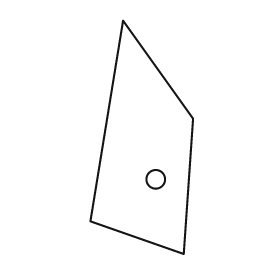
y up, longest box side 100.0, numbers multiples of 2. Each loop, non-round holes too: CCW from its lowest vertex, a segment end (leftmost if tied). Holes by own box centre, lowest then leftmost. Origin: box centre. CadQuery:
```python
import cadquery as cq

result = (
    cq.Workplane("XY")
    .moveTo(18.0, -50.0)
    .lineTo(22.0, 8.0)
    .lineTo(-8.0, 50.0)
    .lineTo(-22.0, -36.0)
    .close()
    .moveTo(6.0, -18.0)
    .circle(4.0)
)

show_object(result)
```